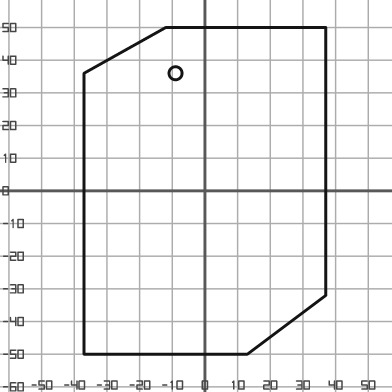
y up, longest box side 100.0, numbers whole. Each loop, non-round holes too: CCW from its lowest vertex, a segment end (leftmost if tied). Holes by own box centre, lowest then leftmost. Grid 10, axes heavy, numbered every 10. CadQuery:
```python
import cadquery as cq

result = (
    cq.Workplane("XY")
    .moveTo(-37.0, -50.0)
    .lineTo(13.0, -50.0)
    .lineTo(37.0, -32.0)
    .lineTo(37.0, 50.0)
    .lineTo(-12.0, 50.0)
    .lineTo(-37.0, 36.0)
    .close()
    .moveTo(-9.0, 36.0)
    .circle(2.0)
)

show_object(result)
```